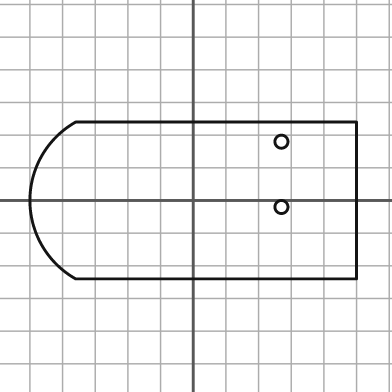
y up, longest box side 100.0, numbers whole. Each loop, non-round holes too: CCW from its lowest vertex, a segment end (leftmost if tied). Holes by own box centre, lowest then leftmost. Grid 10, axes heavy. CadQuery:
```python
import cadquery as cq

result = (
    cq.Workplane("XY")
    .moveTo(-36.0, -24.0)
    .lineTo(50.0, -24.0)
    .lineTo(50.0, 24.0)
    .lineTo(-36.0, 24.0)
    .threePointArc((-50.0, 0.0), (-36.0, -24.0))
    .close()
    .moveTo(27.0, -2.0)
    .circle(2.0)
    .moveTo(27.0, 18.0)
    .circle(2.0)
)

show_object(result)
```